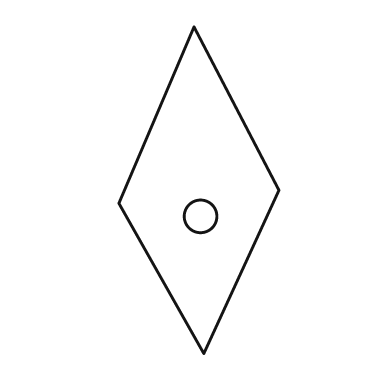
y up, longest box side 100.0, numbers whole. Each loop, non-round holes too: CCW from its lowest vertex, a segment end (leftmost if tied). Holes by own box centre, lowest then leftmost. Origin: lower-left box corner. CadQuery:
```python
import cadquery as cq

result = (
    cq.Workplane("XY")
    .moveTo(26.0, 0.0)
    .lineTo(49.0, 50.0)
    .lineTo(23.0, 100.0)
    .lineTo(0.0, 46.0)
    .close()
    .moveTo(25.0, 42.0)
    .circle(5.0)
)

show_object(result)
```